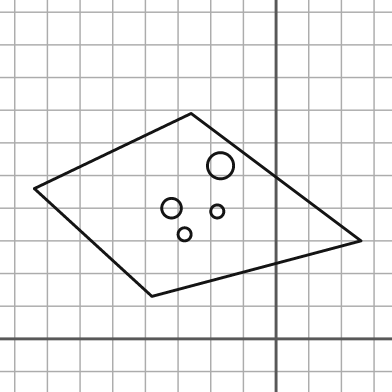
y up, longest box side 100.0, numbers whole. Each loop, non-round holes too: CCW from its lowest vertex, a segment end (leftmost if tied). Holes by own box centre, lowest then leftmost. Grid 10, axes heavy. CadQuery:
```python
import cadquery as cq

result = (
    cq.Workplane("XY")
    .moveTo(-38.0, 13.0)
    .lineTo(26.0, 30.0)
    .lineTo(-26.0, 69.0)
    .lineTo(-74.0, 46.0)
    .close()
    .moveTo(-28.0, 32.0)
    .circle(2.0)
    .moveTo(-18.0, 39.0)
    .circle(2.0)
    .moveTo(-32.0, 40.0)
    .circle(3.0)
    .moveTo(-17.0, 53.0)
    .circle(4.0)
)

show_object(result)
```